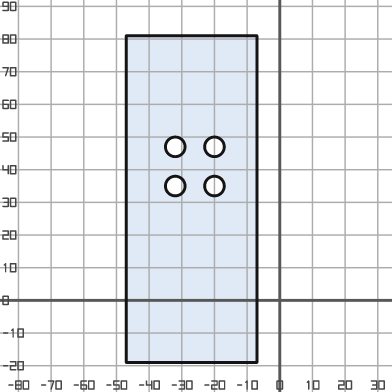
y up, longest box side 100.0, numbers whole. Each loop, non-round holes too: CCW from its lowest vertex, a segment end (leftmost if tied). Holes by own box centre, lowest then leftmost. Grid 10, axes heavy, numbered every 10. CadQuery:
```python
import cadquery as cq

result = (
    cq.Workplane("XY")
    .moveTo(-47.0, -19.0)
    .lineTo(-7.0, -19.0)
    .lineTo(-7.0, 81.0)
    .lineTo(-47.0, 81.0)
    .close()
    .moveTo(-32.0, 35.0)
    .circle(3.0)
    .moveTo(-20.0, 35.0)
    .circle(3.0)
    .moveTo(-32.0, 47.0)
    .circle(3.0)
    .moveTo(-20.0, 47.0)
    .circle(3.0)
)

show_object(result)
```